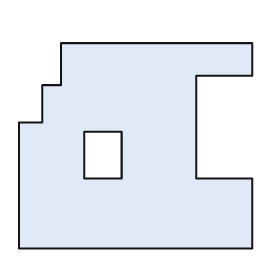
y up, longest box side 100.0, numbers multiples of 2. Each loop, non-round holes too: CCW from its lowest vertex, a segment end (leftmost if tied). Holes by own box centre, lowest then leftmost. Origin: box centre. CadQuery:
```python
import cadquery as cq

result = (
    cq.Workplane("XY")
    .moveTo(-50.0, -44.0)
    .lineTo(50.0, -44.0)
    .lineTo(50.0, -14.0)
    .lineTo(26.0, -14.0)
    .lineTo(26.0, 30.0)
    .lineTo(50.0, 30.0)
    .lineTo(50.0, 44.0)
    .lineTo(-32.0, 44.0)
    .lineTo(-32.0, 26.0)
    .lineTo(-40.0, 26.0)
    .lineTo(-40.0, 10.0)
    .lineTo(-50.0, 10.0)
    .close()
    .moveTo(-22.0, -14.0)
    .lineTo(-6.0, -14.0)
    .lineTo(-6.0, 6.0)
    .lineTo(-22.0, 6.0)
    .close()
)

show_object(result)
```